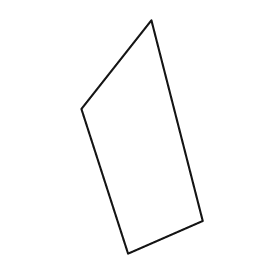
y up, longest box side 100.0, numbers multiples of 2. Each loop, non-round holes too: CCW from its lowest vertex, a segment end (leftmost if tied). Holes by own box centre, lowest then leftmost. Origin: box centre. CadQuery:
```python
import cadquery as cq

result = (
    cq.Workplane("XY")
    .moveTo(-6.0, -50.0)
    .lineTo(26.0, -36.0)
    .lineTo(4.0, 50.0)
    .lineTo(-26.0, 12.0)
    .close()
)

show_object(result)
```